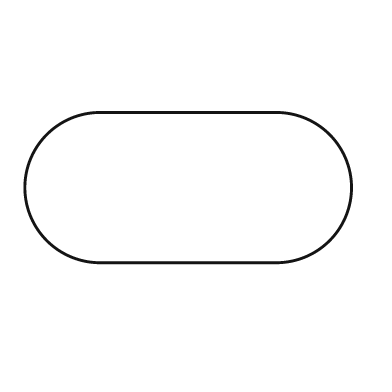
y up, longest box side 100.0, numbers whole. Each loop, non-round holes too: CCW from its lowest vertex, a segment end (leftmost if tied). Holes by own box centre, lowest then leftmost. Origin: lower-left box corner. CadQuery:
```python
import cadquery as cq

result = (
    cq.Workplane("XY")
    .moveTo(23.0, 0.0)
    .lineTo(77.0, 0.0)
    .threePointArc((100.0, 23.0), (77.0, 46.0))
    .lineTo(23.0, 46.0)
    .threePointArc((0.0, 23.0), (23.0, 0.0))
    .close()
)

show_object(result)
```